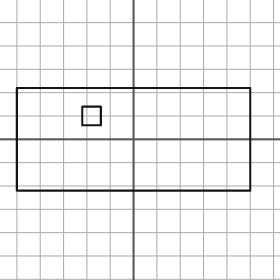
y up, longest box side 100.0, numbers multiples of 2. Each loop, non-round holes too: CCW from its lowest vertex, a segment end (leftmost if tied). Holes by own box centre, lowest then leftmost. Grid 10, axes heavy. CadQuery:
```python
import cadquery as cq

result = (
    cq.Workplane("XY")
    .moveTo(-50.0, -22.0)
    .lineTo(50.0, -22.0)
    .lineTo(50.0, 22.0)
    .lineTo(-50.0, 22.0)
    .close()
    .moveTo(-22.0, 6.0)
    .lineTo(-14.0, 6.0)
    .lineTo(-14.0, 14.0)
    .lineTo(-22.0, 14.0)
    .close()
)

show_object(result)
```